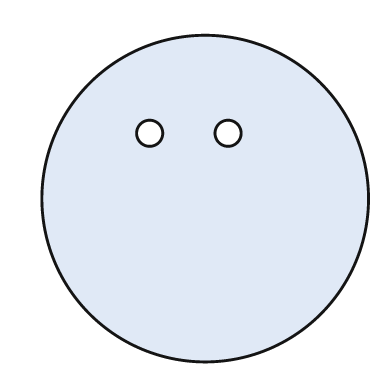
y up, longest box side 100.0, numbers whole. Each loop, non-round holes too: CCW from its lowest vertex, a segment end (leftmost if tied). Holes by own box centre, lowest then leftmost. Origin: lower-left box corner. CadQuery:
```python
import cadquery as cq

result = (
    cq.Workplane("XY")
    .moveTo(50.0, 50.0)
    .circle(50.0)
    .moveTo(33.0, 70.0)
    .circle(4.0)
    .moveTo(57.0, 70.0)
    .circle(4.0)
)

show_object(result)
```